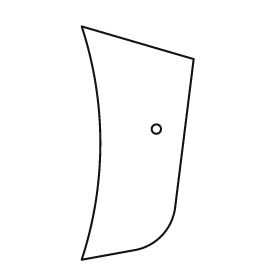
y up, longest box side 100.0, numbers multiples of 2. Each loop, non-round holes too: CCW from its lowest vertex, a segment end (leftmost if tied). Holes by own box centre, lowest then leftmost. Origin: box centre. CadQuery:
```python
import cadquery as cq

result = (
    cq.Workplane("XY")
    .moveTo(-24.0, -50.0)
    .lineTo(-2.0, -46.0)
    .threePointArc((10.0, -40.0), (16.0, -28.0))
    .lineTo(24.0, 36.0)
    .lineTo(-24.0, 50.0)
    .threePointArc((-16.0, 0.0), (-24.0, -50.0))
    .close()
    .moveTo(8.0, 6.0)
    .circle(2.0)
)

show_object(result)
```